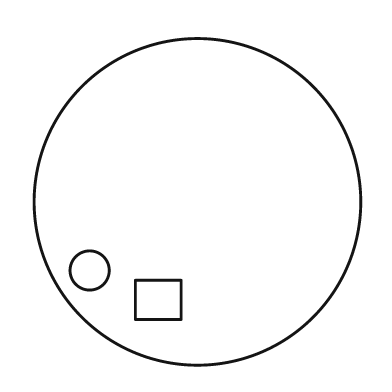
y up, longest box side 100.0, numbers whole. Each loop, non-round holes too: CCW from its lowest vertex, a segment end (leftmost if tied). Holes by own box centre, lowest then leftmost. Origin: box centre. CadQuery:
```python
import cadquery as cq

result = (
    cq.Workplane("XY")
    .moveTo(0.0, 0.0)
    .circle(50.0)
    .moveTo(-19.0, -36.0)
    .lineTo(-5.0, -36.0)
    .lineTo(-5.0, -24.0)
    .lineTo(-19.0, -24.0)
    .close()
    .moveTo(-33.0, -21.0)
    .circle(6.0)
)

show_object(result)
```